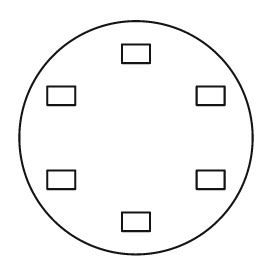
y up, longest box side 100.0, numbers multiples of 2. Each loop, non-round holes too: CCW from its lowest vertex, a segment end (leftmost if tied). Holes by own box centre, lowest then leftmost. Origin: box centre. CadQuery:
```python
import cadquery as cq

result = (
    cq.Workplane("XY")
    .moveTo(0.0, 0.0)
    .circle(50.0)
    .moveTo(-6.0, -40.0)
    .lineTo(6.0, -40.0)
    .lineTo(6.0, -32.0)
    .lineTo(-6.0, -32.0)
    .close()
    .moveTo(-38.0, -22.0)
    .lineTo(-26.0, -22.0)
    .lineTo(-26.0, -14.0)
    .lineTo(-38.0, -14.0)
    .close()
    .moveTo(26.0, -22.0)
    .lineTo(38.0, -22.0)
    .lineTo(38.0, -14.0)
    .lineTo(26.0, -14.0)
    .close()
    .moveTo(-38.0, 14.0)
    .lineTo(-26.0, 14.0)
    .lineTo(-26.0, 22.0)
    .lineTo(-38.0, 22.0)
    .close()
    .moveTo(26.0, 14.0)
    .lineTo(38.0, 14.0)
    .lineTo(38.0, 22.0)
    .lineTo(26.0, 22.0)
    .close()
    .moveTo(-6.0, 32.0)
    .lineTo(6.0, 32.0)
    .lineTo(6.0, 40.0)
    .lineTo(-6.0, 40.0)
    .close()
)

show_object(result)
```